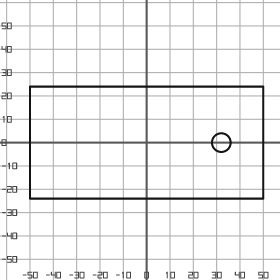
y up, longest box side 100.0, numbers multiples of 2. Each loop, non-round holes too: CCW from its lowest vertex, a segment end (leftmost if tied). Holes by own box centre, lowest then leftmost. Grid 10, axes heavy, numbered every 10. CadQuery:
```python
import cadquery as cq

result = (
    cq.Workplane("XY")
    .moveTo(-50.0, -24.0)
    .lineTo(50.0, -24.0)
    .lineTo(50.0, 24.0)
    .lineTo(-50.0, 24.0)
    .close()
    .moveTo(32.0, 0.0)
    .circle(4.0)
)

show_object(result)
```